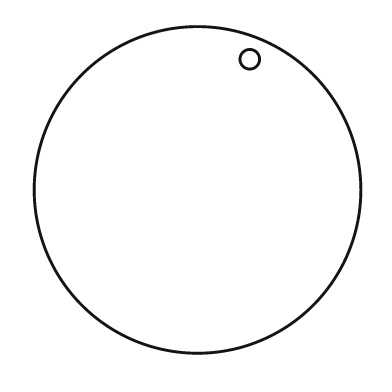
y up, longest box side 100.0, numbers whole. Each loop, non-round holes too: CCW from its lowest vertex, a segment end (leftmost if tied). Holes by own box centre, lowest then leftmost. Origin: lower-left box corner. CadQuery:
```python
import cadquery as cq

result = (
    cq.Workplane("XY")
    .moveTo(50.0, 50.0)
    .circle(50.0)
    .moveTo(66.0, 90.0)
    .circle(3.0)
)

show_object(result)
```